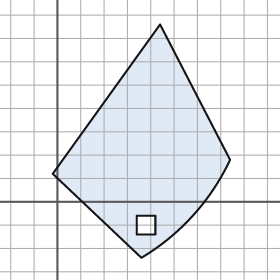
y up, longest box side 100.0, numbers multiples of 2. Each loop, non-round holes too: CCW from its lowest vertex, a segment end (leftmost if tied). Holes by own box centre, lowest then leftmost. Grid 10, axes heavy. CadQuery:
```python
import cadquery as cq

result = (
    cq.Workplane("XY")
    .moveTo(36.0, -24.0)
    .threePointArc((58.0, -6.0), (74.0, 18.0))
    .lineTo(44.0, 76.0)
    .lineTo(-2.0, 12.0)
    .close()
    .moveTo(34.0, -14.0)
    .lineTo(42.0, -14.0)
    .lineTo(42.0, -6.0)
    .lineTo(34.0, -6.0)
    .close()
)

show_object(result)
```